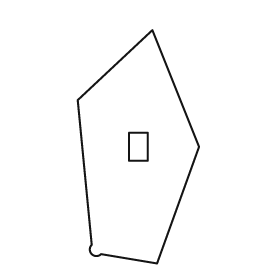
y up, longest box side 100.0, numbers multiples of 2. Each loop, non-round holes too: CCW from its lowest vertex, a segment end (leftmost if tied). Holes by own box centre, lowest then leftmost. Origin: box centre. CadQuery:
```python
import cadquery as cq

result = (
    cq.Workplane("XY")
    .moveTo(8.0, -50.0)
    .lineTo(26.0, 0.0)
    .lineTo(6.0, 50.0)
    .lineTo(-26.0, 20.0)
    .lineTo(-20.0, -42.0)
    .threePointArc((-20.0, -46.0), (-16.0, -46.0))
    .close()
    .moveTo(-4.0, -6.0)
    .lineTo(4.0, -6.0)
    .lineTo(4.0, 6.0)
    .lineTo(-4.0, 6.0)
    .close()
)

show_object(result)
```